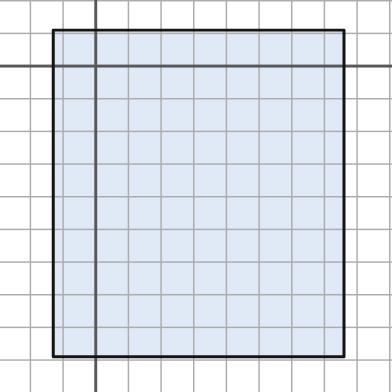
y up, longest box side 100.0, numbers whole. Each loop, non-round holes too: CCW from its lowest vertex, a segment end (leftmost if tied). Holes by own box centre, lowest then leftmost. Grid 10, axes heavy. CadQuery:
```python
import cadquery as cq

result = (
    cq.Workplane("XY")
    .moveTo(-13.0, -89.0)
    .lineTo(76.0, -89.0)
    .lineTo(76.0, 11.0)
    .lineTo(-13.0, 11.0)
    .close()
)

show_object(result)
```